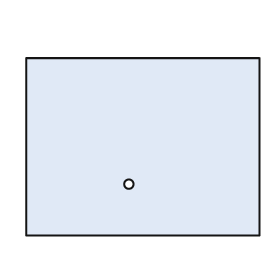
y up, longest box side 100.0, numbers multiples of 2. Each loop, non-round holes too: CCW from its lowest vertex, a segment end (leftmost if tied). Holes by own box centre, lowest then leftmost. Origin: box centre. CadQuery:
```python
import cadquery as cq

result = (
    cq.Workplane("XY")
    .moveTo(-50.0, -38.0)
    .lineTo(50.0, -38.0)
    .lineTo(50.0, 38.0)
    .lineTo(-50.0, 38.0)
    .close()
    .moveTo(-6.0, -16.0)
    .circle(2.0)
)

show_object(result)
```